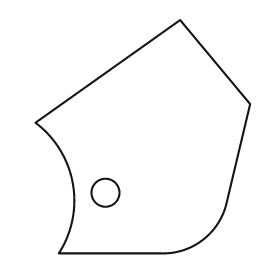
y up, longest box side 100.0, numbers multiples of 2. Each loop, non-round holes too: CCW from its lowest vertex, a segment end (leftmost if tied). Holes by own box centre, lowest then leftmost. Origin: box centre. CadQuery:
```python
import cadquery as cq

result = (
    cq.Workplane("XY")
    .moveTo(-36.0, -50.0)
    .lineTo(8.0, -50.0)
    .threePointArc((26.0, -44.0), (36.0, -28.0))
    .lineTo(46.0, 14.0)
    .lineTo(16.0, 50.0)
    .lineTo(-46.0, 6.0)
    .threePointArc((-30.0, -20.0), (-36.0, -50.0))
    .close()
    .moveTo(-16.0, -24.0)
    .circle(6.0)
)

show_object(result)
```